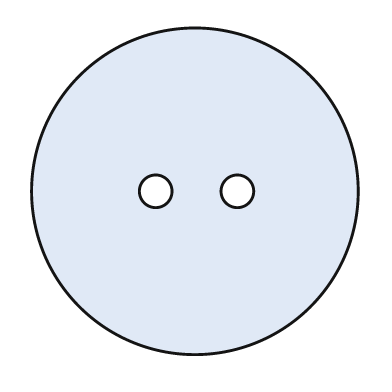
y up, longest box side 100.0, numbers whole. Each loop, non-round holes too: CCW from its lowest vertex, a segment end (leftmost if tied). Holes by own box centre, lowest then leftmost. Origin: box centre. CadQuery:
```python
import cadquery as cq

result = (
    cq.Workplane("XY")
    .moveTo(0.0, 0.0)
    .circle(50.0)
    .moveTo(-12.0, 0.0)
    .circle(5.0)
    .moveTo(13.0, 0.0)
    .circle(5.0)
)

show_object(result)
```